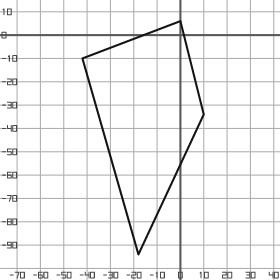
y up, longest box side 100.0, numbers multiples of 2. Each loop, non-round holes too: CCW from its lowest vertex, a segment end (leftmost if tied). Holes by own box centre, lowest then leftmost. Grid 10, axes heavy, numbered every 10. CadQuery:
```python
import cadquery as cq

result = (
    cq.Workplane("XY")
    .moveTo(-18.0, -94.0)
    .lineTo(10.0, -34.0)
    .lineTo(0.0, 6.0)
    .lineTo(-42.0, -10.0)
    .close()
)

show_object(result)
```